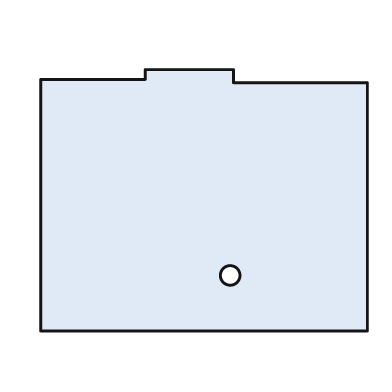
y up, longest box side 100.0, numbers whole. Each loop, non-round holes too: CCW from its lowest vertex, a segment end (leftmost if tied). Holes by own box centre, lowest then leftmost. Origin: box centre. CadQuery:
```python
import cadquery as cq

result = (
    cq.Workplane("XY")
    .moveTo(-50.0, -40.0)
    .lineTo(50.0, -40.0)
    .lineTo(50.0, 36.0)
    .lineTo(9.0, 36.0)
    .lineTo(9.0, 40.0)
    .lineTo(-18.0, 40.0)
    .lineTo(-18.0, 37.0)
    .lineTo(-50.0, 37.0)
    .close()
    .moveTo(8.0, -23.0)
    .circle(3.0)
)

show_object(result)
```